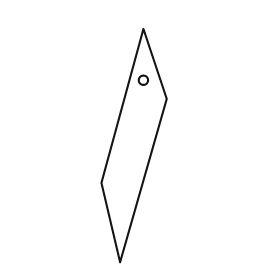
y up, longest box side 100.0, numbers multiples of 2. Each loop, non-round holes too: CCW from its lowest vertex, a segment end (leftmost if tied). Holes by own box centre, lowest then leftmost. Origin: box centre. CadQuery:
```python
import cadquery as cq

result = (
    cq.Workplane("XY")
    .moveTo(-6.0, -50.0)
    .lineTo(14.0, 20.0)
    .lineTo(4.0, 50.0)
    .lineTo(-14.0, -16.0)
    .close()
    .moveTo(4.0, 28.0)
    .circle(2.0)
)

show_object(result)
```